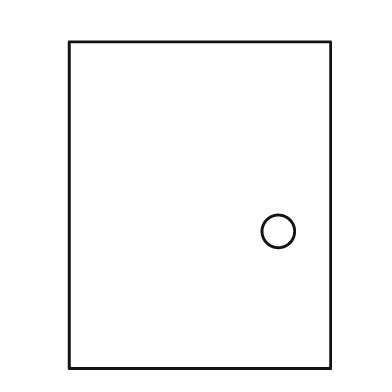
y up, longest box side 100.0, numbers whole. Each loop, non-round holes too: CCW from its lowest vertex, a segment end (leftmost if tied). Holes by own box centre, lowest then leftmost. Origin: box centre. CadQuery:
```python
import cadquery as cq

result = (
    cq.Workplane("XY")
    .moveTo(-40.0, -50.0)
    .lineTo(40.0, -50.0)
    .lineTo(40.0, 50.0)
    .lineTo(-40.0, 50.0)
    .close()
    .moveTo(24.0, -8.0)
    .circle(5.0)
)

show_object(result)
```